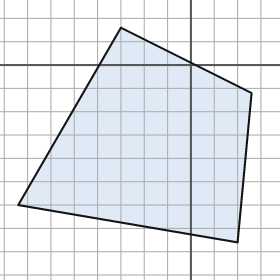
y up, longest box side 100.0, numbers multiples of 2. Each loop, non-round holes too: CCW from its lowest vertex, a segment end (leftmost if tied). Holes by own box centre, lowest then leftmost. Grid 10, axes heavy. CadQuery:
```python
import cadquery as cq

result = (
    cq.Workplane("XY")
    .moveTo(20.0, -76.0)
    .lineTo(26.0, -12.0)
    .lineTo(-30.0, 16.0)
    .lineTo(-74.0, -60.0)
    .close()
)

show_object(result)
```